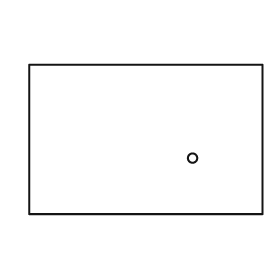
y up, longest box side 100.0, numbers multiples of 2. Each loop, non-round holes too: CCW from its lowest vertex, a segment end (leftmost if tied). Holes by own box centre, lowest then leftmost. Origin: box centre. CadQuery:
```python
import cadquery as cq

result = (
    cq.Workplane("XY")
    .moveTo(-50.0, -32.0)
    .lineTo(50.0, -32.0)
    .lineTo(50.0, 32.0)
    .lineTo(-50.0, 32.0)
    .close()
    .moveTo(20.0, -8.0)
    .circle(2.0)
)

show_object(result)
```